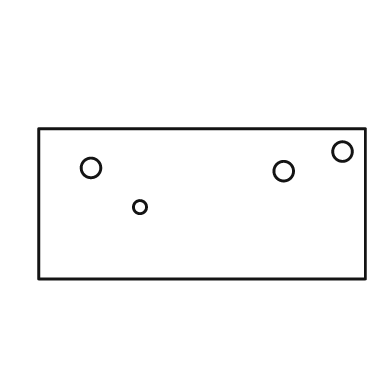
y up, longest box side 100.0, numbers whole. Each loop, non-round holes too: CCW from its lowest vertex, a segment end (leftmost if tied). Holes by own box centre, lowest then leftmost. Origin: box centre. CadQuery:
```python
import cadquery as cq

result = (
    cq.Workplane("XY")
    .moveTo(-50.0, -23.0)
    .lineTo(50.0, -23.0)
    .lineTo(50.0, 23.0)
    .lineTo(-50.0, 23.0)
    .close()
    .moveTo(-19.0, -1.0)
    .circle(2.0)
    .moveTo(25.0, 10.0)
    .circle(3.0)
    .moveTo(-34.0, 11.0)
    .circle(3.0)
    .moveTo(43.0, 16.0)
    .circle(3.0)
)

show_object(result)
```